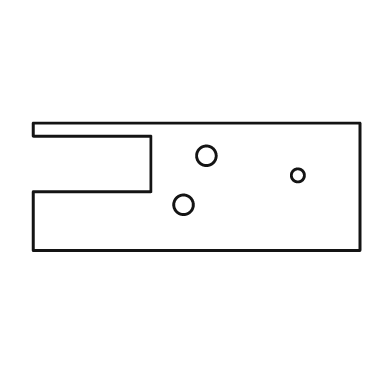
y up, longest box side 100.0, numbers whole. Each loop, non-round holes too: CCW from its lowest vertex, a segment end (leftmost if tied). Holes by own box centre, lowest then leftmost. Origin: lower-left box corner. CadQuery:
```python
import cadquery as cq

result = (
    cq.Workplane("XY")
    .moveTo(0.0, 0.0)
    .lineTo(100.0, 0.0)
    .lineTo(100.0, 39.0)
    .lineTo(0.0, 39.0)
    .lineTo(0.0, 35.0)
    .lineTo(36.0, 35.0)
    .lineTo(36.0, 18.0)
    .lineTo(0.0, 18.0)
    .close()
    .moveTo(46.0, 14.0)
    .circle(3.0)
    .moveTo(81.0, 23.0)
    .circle(2.0)
    .moveTo(53.0, 29.0)
    .circle(3.0)
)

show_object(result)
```